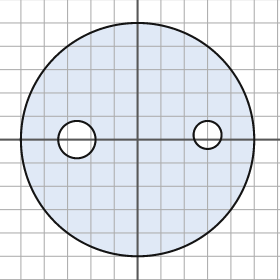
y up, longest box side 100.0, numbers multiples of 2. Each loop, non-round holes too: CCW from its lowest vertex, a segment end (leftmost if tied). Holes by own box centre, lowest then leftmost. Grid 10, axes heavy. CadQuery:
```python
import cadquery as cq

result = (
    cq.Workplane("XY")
    .moveTo(0.0, 0.0)
    .circle(50.0)
    .moveTo(-26.0, 0.0)
    .circle(8.0)
    .moveTo(30.0, 2.0)
    .circle(6.0)
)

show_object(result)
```